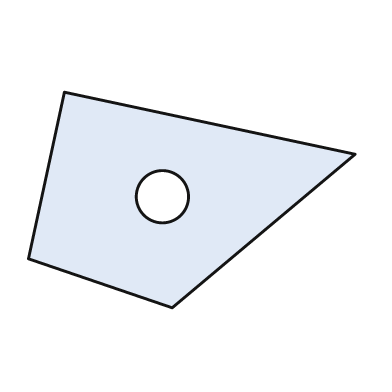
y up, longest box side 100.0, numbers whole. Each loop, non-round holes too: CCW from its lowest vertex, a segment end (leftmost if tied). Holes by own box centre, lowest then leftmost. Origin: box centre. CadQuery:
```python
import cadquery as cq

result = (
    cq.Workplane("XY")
    .moveTo(-6.0, -33.0)
    .lineTo(50.0, 14.0)
    .lineTo(-39.0, 33.0)
    .lineTo(-50.0, -18.0)
    .close()
    .moveTo(-9.0, 1.0)
    .circle(8.0)
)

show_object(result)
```